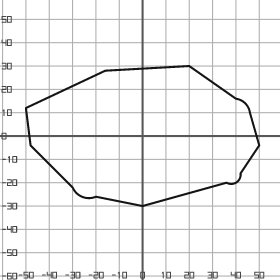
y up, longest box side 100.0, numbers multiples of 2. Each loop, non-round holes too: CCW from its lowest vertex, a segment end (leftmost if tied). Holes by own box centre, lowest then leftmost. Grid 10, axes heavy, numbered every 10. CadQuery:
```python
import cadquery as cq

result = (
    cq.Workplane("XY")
    .moveTo(0.0, -30.0)
    .lineTo(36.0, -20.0)
    .threePointArc((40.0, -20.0), (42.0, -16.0))
    .lineTo(50.0, -4.0)
    .lineTo(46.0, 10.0)
    .threePointArc((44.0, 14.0), (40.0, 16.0))
    .lineTo(20.0, 30.0)
    .lineTo(-16.0, 28.0)
    .lineTo(-50.0, 12.0)
    .lineTo(-48.0, -4.0)
    .lineTo(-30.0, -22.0)
    .threePointArc((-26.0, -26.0), (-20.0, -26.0))
    .close()
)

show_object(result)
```